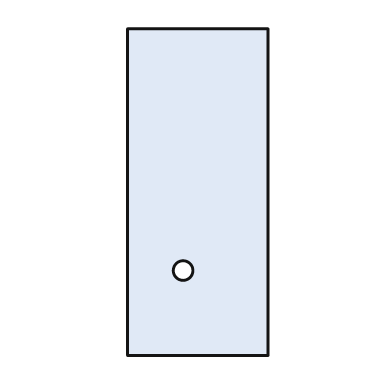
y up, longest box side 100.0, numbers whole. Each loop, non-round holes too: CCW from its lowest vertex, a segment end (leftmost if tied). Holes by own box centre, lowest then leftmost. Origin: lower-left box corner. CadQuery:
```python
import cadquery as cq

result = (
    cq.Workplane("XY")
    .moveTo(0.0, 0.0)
    .lineTo(43.0, 0.0)
    .lineTo(43.0, 100.0)
    .lineTo(0.0, 100.0)
    .close()
    .moveTo(17.0, 26.0)
    .circle(3.0)
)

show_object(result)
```